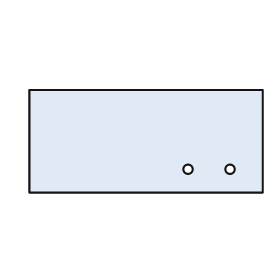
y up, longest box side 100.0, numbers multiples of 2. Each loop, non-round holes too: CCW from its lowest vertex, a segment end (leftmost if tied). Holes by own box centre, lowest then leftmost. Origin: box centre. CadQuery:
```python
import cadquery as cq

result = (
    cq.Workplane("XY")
    .moveTo(-50.0, -22.0)
    .lineTo(50.0, -22.0)
    .lineTo(50.0, 22.0)
    .lineTo(-50.0, 22.0)
    .close()
    .moveTo(18.0, -12.0)
    .circle(2.0)
    .moveTo(36.0, -12.0)
    .circle(2.0)
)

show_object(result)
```